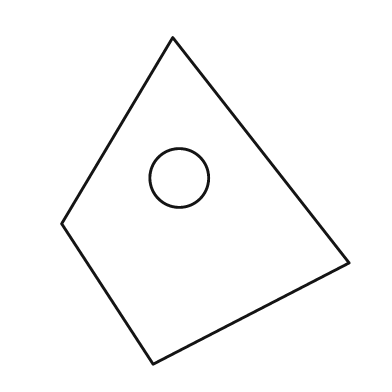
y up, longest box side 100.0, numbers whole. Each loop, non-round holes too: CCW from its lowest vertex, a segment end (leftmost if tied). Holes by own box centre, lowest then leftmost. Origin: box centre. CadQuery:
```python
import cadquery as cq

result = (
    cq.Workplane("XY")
    .moveTo(-16.0, -50.0)
    .lineTo(44.0, -19.0)
    .lineTo(-10.0, 50.0)
    .lineTo(-44.0, -7.0)
    .close()
    .moveTo(-8.0, 7.0)
    .circle(9.0)
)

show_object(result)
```